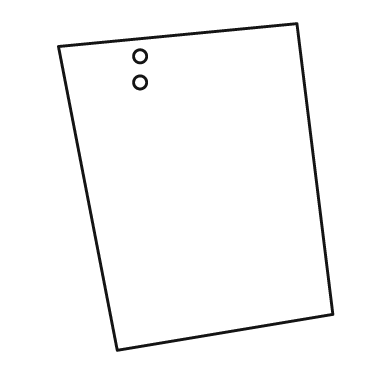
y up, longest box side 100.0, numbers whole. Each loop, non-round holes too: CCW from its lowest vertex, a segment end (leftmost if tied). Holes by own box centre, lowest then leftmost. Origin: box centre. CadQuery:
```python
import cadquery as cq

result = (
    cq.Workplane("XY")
    .moveTo(-24.0, -50.0)
    .lineTo(42.0, -39.0)
    .lineTo(31.0, 50.0)
    .lineTo(-42.0, 43.0)
    .close()
    .moveTo(-17.0, 32.0)
    .circle(2.0)
    .moveTo(-17.0, 40.0)
    .circle(2.0)
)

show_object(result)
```